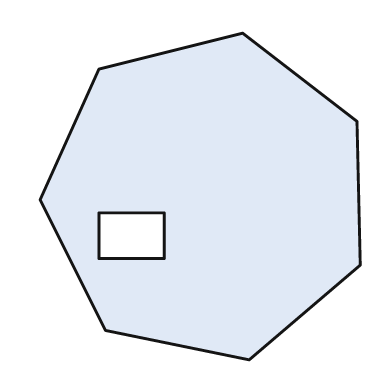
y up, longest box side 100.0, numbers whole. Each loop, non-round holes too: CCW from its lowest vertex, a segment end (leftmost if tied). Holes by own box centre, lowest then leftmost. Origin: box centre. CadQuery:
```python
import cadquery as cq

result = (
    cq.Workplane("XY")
    .moveTo(15.0, -50.0)
    .lineTo(49.0, -21.0)
    .lineTo(48.0, 23.0)
    .lineTo(13.0, 50.0)
    .lineTo(-31.0, 39.0)
    .lineTo(-49.0, -1.0)
    .lineTo(-29.0, -41.0)
    .close()
    .moveTo(-31.0, -19.0)
    .lineTo(-11.0, -19.0)
    .lineTo(-11.0, -5.0)
    .lineTo(-31.0, -5.0)
    .close()
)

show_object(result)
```